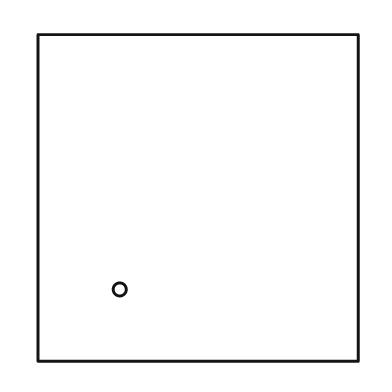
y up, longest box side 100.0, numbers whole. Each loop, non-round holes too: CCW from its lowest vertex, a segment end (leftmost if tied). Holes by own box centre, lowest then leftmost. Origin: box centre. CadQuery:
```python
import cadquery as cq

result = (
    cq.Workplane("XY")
    .moveTo(-49.0, -50.0)
    .lineTo(49.0, -50.0)
    .lineTo(49.0, 50.0)
    .lineTo(-49.0, 50.0)
    .close()
    .moveTo(-24.0, -28.0)
    .circle(2.0)
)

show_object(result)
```